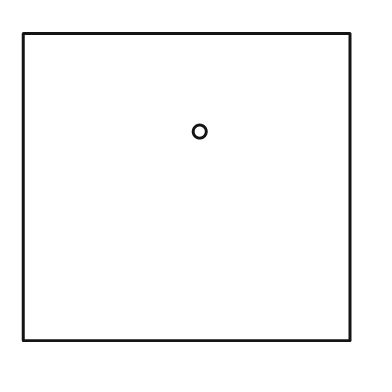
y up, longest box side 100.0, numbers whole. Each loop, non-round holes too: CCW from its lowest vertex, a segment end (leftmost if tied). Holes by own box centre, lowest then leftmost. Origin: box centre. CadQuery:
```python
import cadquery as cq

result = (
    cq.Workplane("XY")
    .moveTo(-50.0, -47.0)
    .lineTo(50.0, -47.0)
    .lineTo(50.0, 47.0)
    .lineTo(-50.0, 47.0)
    .close()
    .moveTo(4.0, 17.0)
    .circle(2.0)
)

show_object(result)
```